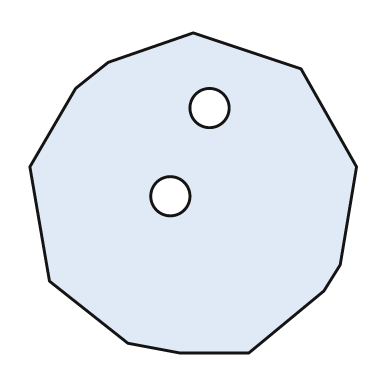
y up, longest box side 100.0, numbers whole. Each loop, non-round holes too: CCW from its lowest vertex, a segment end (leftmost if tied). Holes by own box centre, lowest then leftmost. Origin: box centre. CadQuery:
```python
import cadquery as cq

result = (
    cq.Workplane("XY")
    .moveTo(-4.0, -49.0)
    .lineTo(17.0, -49.0)
    .lineTo(40.0, -30.0)
    .lineTo(45.0, -22.0)
    .lineTo(50.0, 8.0)
    .lineTo(33.0, 38.0)
    .lineTo(0.0, 49.0)
    .lineTo(-26.0, 40.0)
    .lineTo(-36.0, 32.0)
    .lineTo(-50.0, 8.0)
    .lineTo(-44.0, -27.0)
    .lineTo(-20.0, -46.0)
    .close()
    .moveTo(-7.0, -1.0)
    .circle(6.0)
    .moveTo(5.0, 26.0)
    .circle(6.0)
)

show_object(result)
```